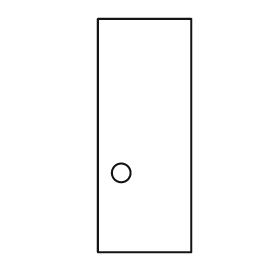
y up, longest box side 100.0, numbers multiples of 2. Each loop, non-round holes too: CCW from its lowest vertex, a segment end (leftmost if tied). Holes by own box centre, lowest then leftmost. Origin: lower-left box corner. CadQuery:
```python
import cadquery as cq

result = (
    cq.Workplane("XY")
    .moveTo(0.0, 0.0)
    .lineTo(40.0, 0.0)
    .lineTo(40.0, 100.0)
    .lineTo(0.0, 100.0)
    .close()
    .moveTo(10.0, 34.0)
    .circle(4.0)
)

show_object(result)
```